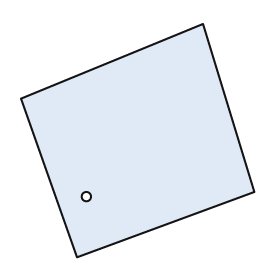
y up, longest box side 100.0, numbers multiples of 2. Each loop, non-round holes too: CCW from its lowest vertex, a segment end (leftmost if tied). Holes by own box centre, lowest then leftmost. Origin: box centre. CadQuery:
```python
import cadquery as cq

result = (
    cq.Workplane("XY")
    .moveTo(-26.0, -50.0)
    .lineTo(50.0, -22.0)
    .lineTo(28.0, 50.0)
    .lineTo(-50.0, 18.0)
    .close()
    .moveTo(-22.0, -24.0)
    .circle(2.0)
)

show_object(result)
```